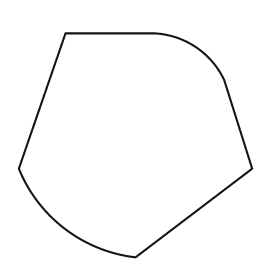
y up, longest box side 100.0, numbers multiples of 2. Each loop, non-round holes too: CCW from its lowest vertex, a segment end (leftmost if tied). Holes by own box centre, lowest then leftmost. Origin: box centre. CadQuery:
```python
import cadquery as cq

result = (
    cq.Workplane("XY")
    .moveTo(0.0, -48.0)
    .lineTo(50.0, -10.0)
    .lineTo(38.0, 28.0)
    .threePointArc((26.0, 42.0), (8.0, 48.0))
    .lineTo(-30.0, 48.0)
    .lineTo(-50.0, -10.0)
    .threePointArc((-30.0, -36.0), (0.0, -48.0))
    .close()
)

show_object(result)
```